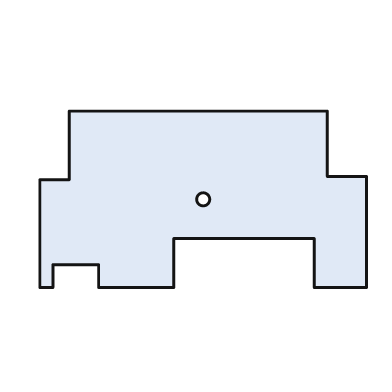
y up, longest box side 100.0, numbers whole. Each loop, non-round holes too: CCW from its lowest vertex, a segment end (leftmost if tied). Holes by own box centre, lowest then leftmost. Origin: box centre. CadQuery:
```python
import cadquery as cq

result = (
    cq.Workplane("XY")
    .moveTo(-50.0, -27.0)
    .lineTo(-46.0, -27.0)
    .lineTo(-46.0, -20.0)
    .lineTo(-32.0, -20.0)
    .lineTo(-32.0, -27.0)
    .lineTo(-9.0, -27.0)
    .lineTo(-9.0, -12.0)
    .lineTo(34.0, -12.0)
    .lineTo(34.0, -27.0)
    .lineTo(50.0, -27.0)
    .lineTo(50.0, 7.0)
    .lineTo(38.0, 7.0)
    .lineTo(38.0, 27.0)
    .lineTo(-41.0, 27.0)
    .lineTo(-41.0, 6.0)
    .lineTo(-50.0, 6.0)
    .close()
    .moveTo(0.0, 0.0)
    .circle(2.0)
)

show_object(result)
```